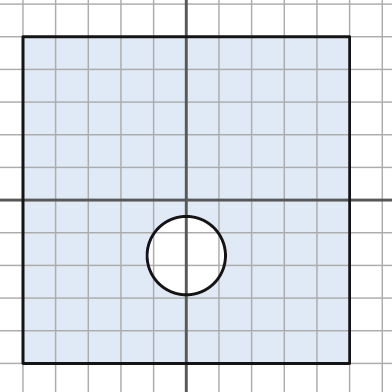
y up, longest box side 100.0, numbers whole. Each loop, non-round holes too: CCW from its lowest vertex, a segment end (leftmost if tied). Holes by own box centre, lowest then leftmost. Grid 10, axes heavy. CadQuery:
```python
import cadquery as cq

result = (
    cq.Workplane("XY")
    .moveTo(-50.0, -50.0)
    .lineTo(50.0, -50.0)
    .lineTo(50.0, 50.0)
    .lineTo(-50.0, 50.0)
    .close()
    .moveTo(0.0, -17.0)
    .circle(12.0)
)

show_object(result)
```